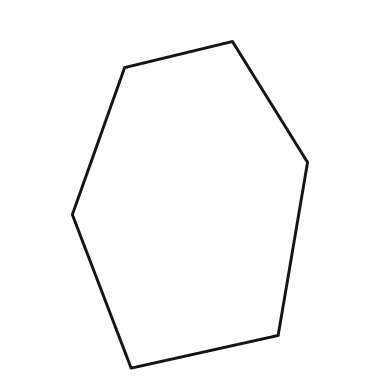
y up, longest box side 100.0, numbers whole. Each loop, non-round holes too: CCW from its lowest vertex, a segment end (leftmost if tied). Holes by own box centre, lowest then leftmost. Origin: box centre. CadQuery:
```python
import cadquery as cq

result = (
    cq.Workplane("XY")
    .moveTo(-18.0, -50.0)
    .lineTo(27.0, -40.0)
    .lineTo(36.0, 13.0)
    .lineTo(13.0, 50.0)
    .lineTo(-20.0, 42.0)
    .lineTo(-36.0, -3.0)
    .close()
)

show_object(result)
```